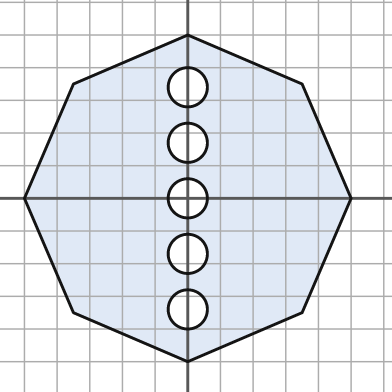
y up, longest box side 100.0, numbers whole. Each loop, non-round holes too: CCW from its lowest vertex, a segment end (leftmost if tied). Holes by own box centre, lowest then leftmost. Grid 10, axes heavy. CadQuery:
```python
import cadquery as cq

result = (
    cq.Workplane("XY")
    .moveTo(0.0, -50.0)
    .lineTo(35.0, -35.0)
    .lineTo(50.0, 0.0)
    .lineTo(35.0, 35.0)
    .lineTo(0.0, 50.0)
    .lineTo(-35.0, 35.0)
    .lineTo(-50.0, 0.0)
    .lineTo(-35.0, -35.0)
    .close()
    .moveTo(0.0, -34.0)
    .circle(6.0)
    .moveTo(0.0, -17.0)
    .circle(6.0)
    .moveTo(0.0, 0.0)
    .circle(6.0)
    .moveTo(0.0, 17.0)
    .circle(6.0)
    .moveTo(0.0, 34.0)
    .circle(6.0)
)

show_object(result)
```